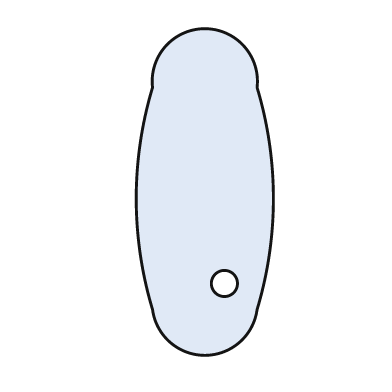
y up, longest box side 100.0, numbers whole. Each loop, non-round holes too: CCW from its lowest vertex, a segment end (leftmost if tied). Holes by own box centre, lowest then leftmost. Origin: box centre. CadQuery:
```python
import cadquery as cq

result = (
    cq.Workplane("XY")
    .moveTo(-16.0, -36.0)
    .threePointArc((0.0, -50.0), (16.0, -36.0))
    .threePointArc((21.0, -2.0), (16.0, 32.0))
    .threePointArc((0.0, 50.0), (-16.0, 32.0))
    .threePointArc((-21.0, -2.0), (-16.0, -36.0))
    .close()
    .moveTo(6.0, -28.0)
    .circle(4.0)
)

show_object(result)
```